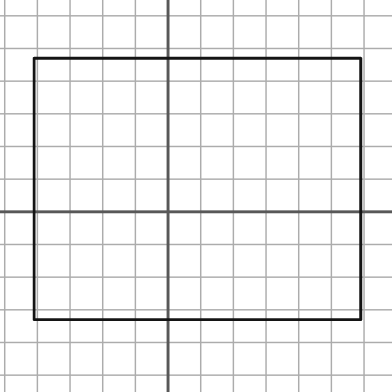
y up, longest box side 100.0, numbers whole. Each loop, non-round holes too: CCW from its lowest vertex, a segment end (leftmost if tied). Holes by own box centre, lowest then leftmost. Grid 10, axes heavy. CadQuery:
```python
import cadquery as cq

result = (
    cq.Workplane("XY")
    .moveTo(-41.0, -33.0)
    .lineTo(59.0, -33.0)
    .lineTo(59.0, 47.0)
    .lineTo(-41.0, 47.0)
    .close()
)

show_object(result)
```